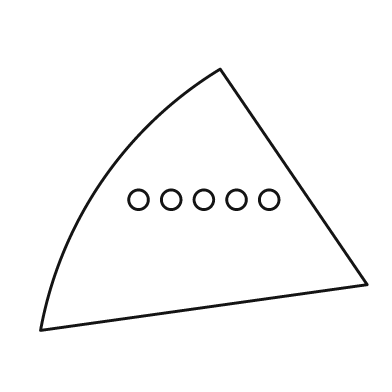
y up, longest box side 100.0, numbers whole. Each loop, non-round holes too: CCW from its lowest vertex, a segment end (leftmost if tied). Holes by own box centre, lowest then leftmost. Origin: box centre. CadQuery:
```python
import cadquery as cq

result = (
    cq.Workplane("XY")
    .moveTo(-50.0, -40.0)
    .lineTo(50.0, -26.0)
    .lineTo(5.0, 40.0)
    .threePointArc((-31.0, 6.0), (-50.0, -40.0))
    .close()
    .moveTo(-20.0, 0.0)
    .circle(3.0)
    .moveTo(-10.0, 0.0)
    .circle(3.0)
    .moveTo(0.0, 0.0)
    .circle(3.0)
    .moveTo(10.0, 0.0)
    .circle(3.0)
    .moveTo(20.0, 0.0)
    .circle(3.0)
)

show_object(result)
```